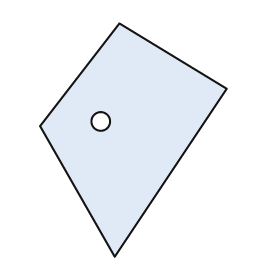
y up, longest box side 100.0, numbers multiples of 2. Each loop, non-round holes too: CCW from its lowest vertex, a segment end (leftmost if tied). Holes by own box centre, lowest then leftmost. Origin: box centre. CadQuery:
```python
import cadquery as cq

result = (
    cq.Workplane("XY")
    .moveTo(-8.0, -50.0)
    .lineTo(40.0, 22.0)
    .lineTo(-6.0, 50.0)
    .lineTo(-40.0, 6.0)
    .close()
    .moveTo(-14.0, 8.0)
    .circle(4.0)
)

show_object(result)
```